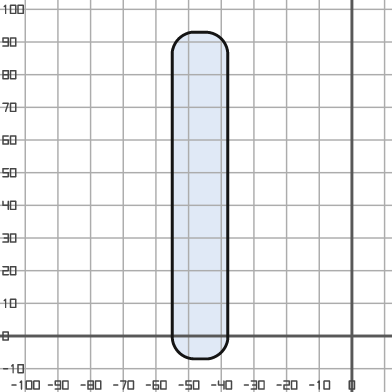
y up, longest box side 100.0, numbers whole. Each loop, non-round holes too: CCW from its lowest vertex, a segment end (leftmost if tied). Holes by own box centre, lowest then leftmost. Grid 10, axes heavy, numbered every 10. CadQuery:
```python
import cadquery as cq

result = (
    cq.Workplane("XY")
    .moveTo(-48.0, -7.0)
    .lineTo(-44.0, -7.0)
    .threePointArc((-40.0, -5.0), (-38.0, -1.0))
    .lineTo(-38.0, 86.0)
    .threePointArc((-40.0, 91.0), (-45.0, 93.0))
    .lineTo(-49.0, 93.0)
    .threePointArc((-53.0, 91.0), (-55.0, 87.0))
    .lineTo(-55.0, 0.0)
    .threePointArc((-53.0, -5.0), (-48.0, -7.0))
    .close()
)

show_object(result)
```